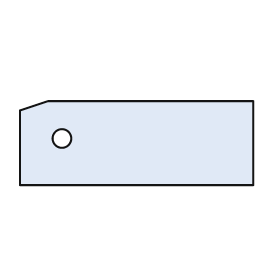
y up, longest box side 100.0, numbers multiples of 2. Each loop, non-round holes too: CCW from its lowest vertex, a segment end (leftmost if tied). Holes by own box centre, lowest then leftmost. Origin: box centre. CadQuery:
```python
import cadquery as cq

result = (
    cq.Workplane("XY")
    .moveTo(-50.0, -18.0)
    .lineTo(50.0, -18.0)
    .lineTo(50.0, 18.0)
    .lineTo(-38.0, 18.0)
    .lineTo(-50.0, 14.0)
    .close()
    .moveTo(-32.0, 2.0)
    .circle(4.0)
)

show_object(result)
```